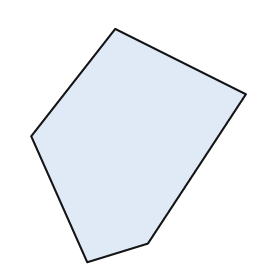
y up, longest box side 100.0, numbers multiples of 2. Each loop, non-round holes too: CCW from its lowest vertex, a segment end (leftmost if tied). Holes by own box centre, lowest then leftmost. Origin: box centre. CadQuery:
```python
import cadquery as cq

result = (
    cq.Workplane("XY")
    .moveTo(-22.0, -50.0)
    .lineTo(4.0, -42.0)
    .lineTo(46.0, 22.0)
    .lineTo(-10.0, 50.0)
    .lineTo(-46.0, 4.0)
    .close()
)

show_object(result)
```